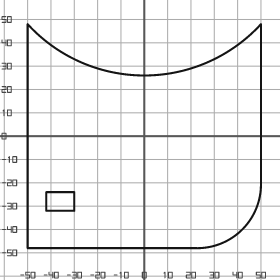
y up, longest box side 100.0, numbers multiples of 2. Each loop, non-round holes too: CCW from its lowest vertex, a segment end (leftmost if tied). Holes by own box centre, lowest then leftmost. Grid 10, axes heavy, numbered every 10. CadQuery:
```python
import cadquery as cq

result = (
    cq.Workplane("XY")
    .moveTo(-50.0, -48.0)
    .lineTo(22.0, -48.0)
    .threePointArc((42.0, -40.0), (50.0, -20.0))
    .lineTo(50.0, 48.0)
    .threePointArc((0.0, 26.0), (-50.0, 48.0))
    .close()
    .moveTo(-42.0, -32.0)
    .lineTo(-30.0, -32.0)
    .lineTo(-30.0, -24.0)
    .lineTo(-42.0, -24.0)
    .close()
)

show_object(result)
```